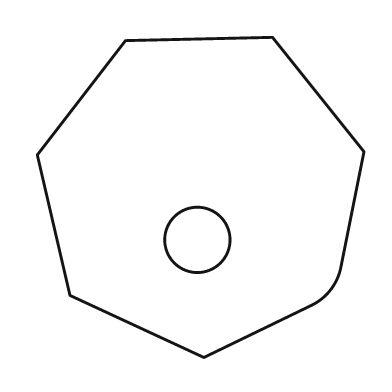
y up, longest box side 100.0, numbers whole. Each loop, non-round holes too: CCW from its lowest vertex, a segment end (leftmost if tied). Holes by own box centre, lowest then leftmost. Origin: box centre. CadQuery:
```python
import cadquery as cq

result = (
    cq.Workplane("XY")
    .moveTo(1.0, -49.0)
    .lineTo(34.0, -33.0)
    .threePointArc((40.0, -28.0), (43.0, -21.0))
    .lineTo(50.0, 14.0)
    .lineTo(22.0, 49.0)
    .lineTo(-23.0, 48.0)
    .lineTo(-50.0, 13.0)
    .lineTo(-40.0, -30.0)
    .close()
    .moveTo(-1.0, -13.0)
    .circle(10.0)
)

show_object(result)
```